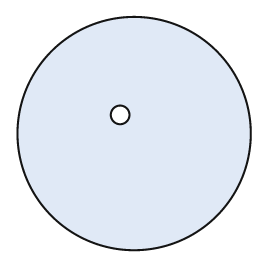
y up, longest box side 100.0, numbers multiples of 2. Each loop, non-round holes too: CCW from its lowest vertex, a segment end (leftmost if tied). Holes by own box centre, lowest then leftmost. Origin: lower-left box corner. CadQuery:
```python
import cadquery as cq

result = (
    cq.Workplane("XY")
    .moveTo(50.0, 50.0)
    .circle(50.0)
    .moveTo(44.0, 58.0)
    .circle(4.0)
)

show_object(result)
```